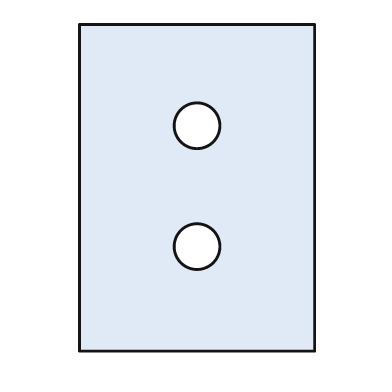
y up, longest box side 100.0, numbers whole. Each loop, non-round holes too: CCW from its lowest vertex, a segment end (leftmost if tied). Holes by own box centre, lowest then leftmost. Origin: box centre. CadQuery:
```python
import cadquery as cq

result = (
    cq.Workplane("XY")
    .moveTo(-36.0, -50.0)
    .lineTo(36.0, -50.0)
    .lineTo(36.0, 50.0)
    .lineTo(-36.0, 50.0)
    .close()
    .moveTo(0.0, -18.0)
    .circle(7.0)
    .moveTo(0.0, 19.0)
    .circle(7.0)
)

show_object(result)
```